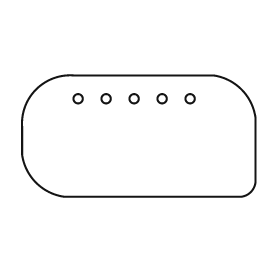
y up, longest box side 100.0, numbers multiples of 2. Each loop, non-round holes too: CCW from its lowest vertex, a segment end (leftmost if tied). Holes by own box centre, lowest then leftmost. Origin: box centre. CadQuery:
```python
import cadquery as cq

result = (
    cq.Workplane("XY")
    .moveTo(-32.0, -26.0)
    .lineTo(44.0, -26.0)
    .threePointArc((48.0, -24.0), (50.0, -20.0))
    .lineTo(50.0, 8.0)
    .threePointArc((44.0, 20.0), (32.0, 26.0))
    .lineTo(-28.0, 26.0)
    .threePointArc((-44.0, 20.0), (-50.0, 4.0))
    .lineTo(-50.0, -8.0)
    .threePointArc((-44.0, -20.0), (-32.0, -26.0))
    .close()
    .moveTo(-26.0, 16.0)
    .circle(2.0)
    .moveTo(-14.0, 16.0)
    .circle(2.0)
    .moveTo(-2.0, 16.0)
    .circle(2.0)
    .moveTo(10.0, 16.0)
    .circle(2.0)
    .moveTo(22.0, 16.0)
    .circle(2.0)
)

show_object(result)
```